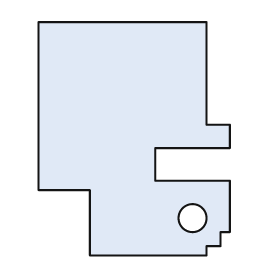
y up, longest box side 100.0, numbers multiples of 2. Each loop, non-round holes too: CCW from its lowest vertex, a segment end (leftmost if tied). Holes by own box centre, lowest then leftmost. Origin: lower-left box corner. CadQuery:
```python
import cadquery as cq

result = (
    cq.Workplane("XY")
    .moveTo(22.0, 0.0)
    .lineTo(72.0, 0.0)
    .lineTo(72.0, 4.0)
    .lineTo(78.0, 4.0)
    .lineTo(78.0, 10.0)
    .lineTo(82.0, 10.0)
    .lineTo(82.0, 32.0)
    .lineTo(50.0, 32.0)
    .lineTo(50.0, 46.0)
    .lineTo(82.0, 46.0)
    .lineTo(82.0, 56.0)
    .lineTo(72.0, 56.0)
    .lineTo(72.0, 100.0)
    .lineTo(0.0, 100.0)
    .lineTo(0.0, 28.0)
    .lineTo(22.0, 28.0)
    .close()
    .moveTo(66.0, 16.0)
    .circle(6.0)
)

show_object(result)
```